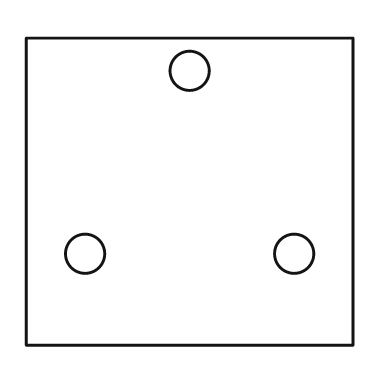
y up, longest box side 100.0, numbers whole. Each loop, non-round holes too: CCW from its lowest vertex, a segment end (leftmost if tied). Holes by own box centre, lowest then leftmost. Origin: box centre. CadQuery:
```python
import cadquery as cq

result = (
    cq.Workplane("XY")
    .moveTo(-50.0, -47.0)
    .lineTo(50.0, -47.0)
    .lineTo(50.0, 47.0)
    .lineTo(-50.0, 47.0)
    .close()
    .moveTo(-32.0, -19.0)
    .circle(6.0)
    .moveTo(32.0, -19.0)
    .circle(6.0)
    .moveTo(0.0, 37.0)
    .circle(6.0)
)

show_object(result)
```